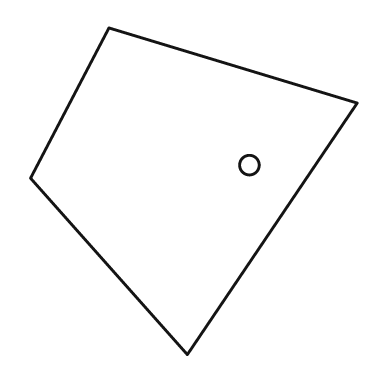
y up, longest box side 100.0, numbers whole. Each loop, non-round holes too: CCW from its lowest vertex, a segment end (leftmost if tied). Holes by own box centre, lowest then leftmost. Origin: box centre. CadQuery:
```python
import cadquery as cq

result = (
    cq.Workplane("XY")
    .moveTo(-2.0, -50.0)
    .lineTo(50.0, 27.0)
    .lineTo(-26.0, 50.0)
    .lineTo(-50.0, 4.0)
    .close()
    .moveTo(17.0, 8.0)
    .circle(3.0)
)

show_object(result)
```